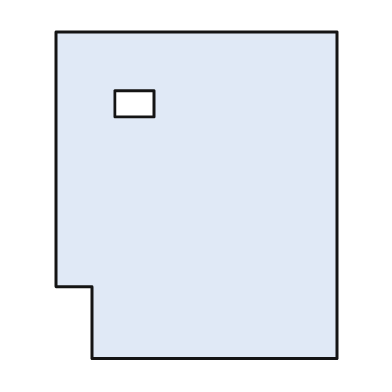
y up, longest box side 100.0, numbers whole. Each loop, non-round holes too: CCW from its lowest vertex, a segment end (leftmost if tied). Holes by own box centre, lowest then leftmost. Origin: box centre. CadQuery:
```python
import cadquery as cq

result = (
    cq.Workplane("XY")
    .moveTo(-32.0, -50.0)
    .lineTo(43.0, -50.0)
    .lineTo(43.0, 50.0)
    .lineTo(-43.0, 50.0)
    .lineTo(-43.0, -28.0)
    .lineTo(-32.0, -28.0)
    .close()
    .moveTo(-25.0, 24.0)
    .lineTo(-13.0, 24.0)
    .lineTo(-13.0, 32.0)
    .lineTo(-25.0, 32.0)
    .close()
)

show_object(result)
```